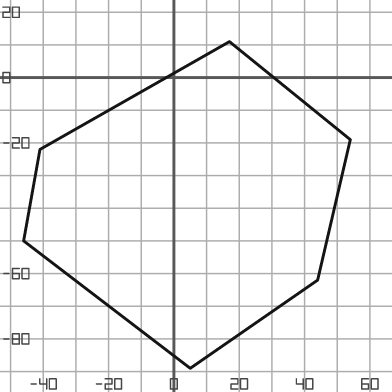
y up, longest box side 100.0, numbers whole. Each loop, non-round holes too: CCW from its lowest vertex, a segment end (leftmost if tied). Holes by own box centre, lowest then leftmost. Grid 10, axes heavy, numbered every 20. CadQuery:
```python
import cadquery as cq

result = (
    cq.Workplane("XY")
    .moveTo(5.0, -89.0)
    .lineTo(44.0, -62.0)
    .lineTo(54.0, -19.0)
    .lineTo(17.0, 11.0)
    .lineTo(-41.0, -22.0)
    .lineTo(-46.0, -50.0)
    .close()
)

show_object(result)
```